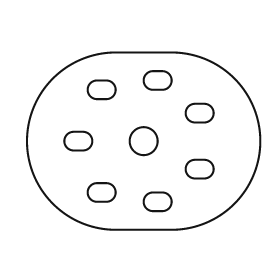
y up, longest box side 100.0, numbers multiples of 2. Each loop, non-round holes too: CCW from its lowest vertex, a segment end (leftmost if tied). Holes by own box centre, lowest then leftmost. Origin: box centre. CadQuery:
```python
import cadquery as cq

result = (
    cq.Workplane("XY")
    .moveTo(-12.0, -38.0)
    .lineTo(12.0, -38.0)
    .threePointArc((50.0, 0.0), (12.0, 38.0))
    .lineTo(-12.0, 38.0)
    .threePointArc((-50.0, 0.0), (-12.0, -38.0))
    .close()
    .moveTo(4.0, -30.0)
    .lineTo(8.0, -30.0)
    .threePointArc((12.0, -26.0), (8.0, -22.0))
    .lineTo(4.0, -22.0)
    .threePointArc((0.0, -26.0), (4.0, -30.0))
    .close()
    .moveTo(-20.0, -26.0)
    .lineTo(-16.0, -26.0)
    .threePointArc((-12.0, -22.0), (-16.0, -18.0))
    .lineTo(-20.0, -18.0)
    .threePointArc((-24.0, -22.0), (-20.0, -26.0))
    .close()
    .moveTo(22.0, -16.0)
    .lineTo(26.0, -16.0)
    .threePointArc((30.0, -12.0), (26.0, -8.0))
    .lineTo(22.0, -8.0)
    .threePointArc((18.0, -12.0), (22.0, -16.0))
    .close()
    .moveTo(-30.0, -4.0)
    .lineTo(-26.0, -4.0)
    .threePointArc((-22.0, 0.0), (-26.0, 4.0))
    .lineTo(-30.0, 4.0)
    .threePointArc((-34.0, 0.0), (-30.0, -4.0))
    .close()
    .moveTo(0.0, 0.0)
    .circle(6.0)
    .moveTo(22.0, 8.0)
    .lineTo(26.0, 8.0)
    .threePointArc((30.0, 12.0), (26.0, 16.0))
    .lineTo(22.0, 16.0)
    .threePointArc((18.0, 12.0), (22.0, 8.0))
    .close()
    .moveTo(-20.0, 18.0)
    .lineTo(-16.0, 18.0)
    .threePointArc((-12.0, 22.0), (-16.0, 26.0))
    .lineTo(-20.0, 26.0)
    .threePointArc((-24.0, 22.0), (-20.0, 18.0))
    .close()
    .moveTo(4.0, 22.0)
    .lineTo(8.0, 22.0)
    .threePointArc((12.0, 26.0), (8.0, 30.0))
    .lineTo(4.0, 30.0)
    .threePointArc((0.0, 26.0), (4.0, 22.0))
    .close()
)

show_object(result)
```